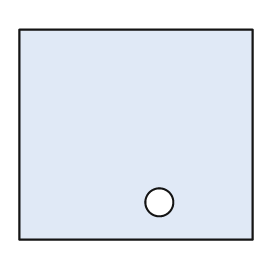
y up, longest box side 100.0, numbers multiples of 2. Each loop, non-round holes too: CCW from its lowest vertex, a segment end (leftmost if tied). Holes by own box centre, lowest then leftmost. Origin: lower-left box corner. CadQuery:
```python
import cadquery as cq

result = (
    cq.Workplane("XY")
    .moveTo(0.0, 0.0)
    .lineTo(100.0, 0.0)
    .lineTo(100.0, 90.0)
    .lineTo(0.0, 90.0)
    .close()
    .moveTo(60.0, 16.0)
    .circle(6.0)
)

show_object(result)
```